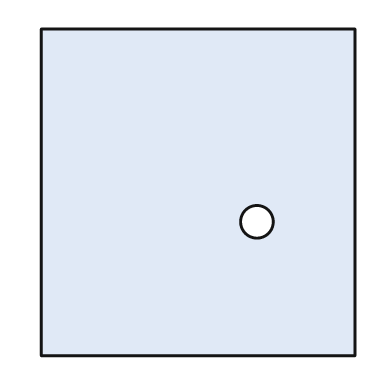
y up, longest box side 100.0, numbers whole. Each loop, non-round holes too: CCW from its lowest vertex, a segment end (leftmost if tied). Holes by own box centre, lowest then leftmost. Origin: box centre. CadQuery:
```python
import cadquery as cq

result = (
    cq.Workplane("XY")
    .moveTo(-48.0, -50.0)
    .lineTo(48.0, -50.0)
    .lineTo(48.0, 50.0)
    .lineTo(-48.0, 50.0)
    .close()
    .moveTo(18.0, -9.0)
    .circle(5.0)
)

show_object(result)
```